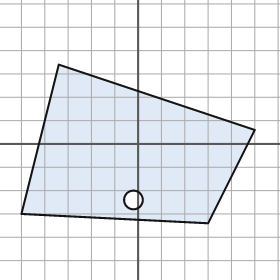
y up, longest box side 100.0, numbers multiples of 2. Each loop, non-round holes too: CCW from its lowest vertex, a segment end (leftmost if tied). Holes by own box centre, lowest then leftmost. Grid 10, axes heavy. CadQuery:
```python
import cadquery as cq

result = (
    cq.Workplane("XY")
    .moveTo(30.0, -34.0)
    .lineTo(50.0, 6.0)
    .lineTo(-34.0, 34.0)
    .lineTo(-50.0, -30.0)
    .close()
    .moveTo(-2.0, -24.0)
    .circle(4.0)
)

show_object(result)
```